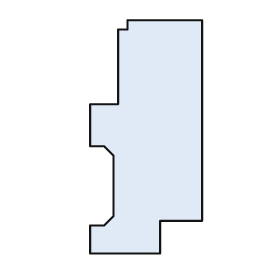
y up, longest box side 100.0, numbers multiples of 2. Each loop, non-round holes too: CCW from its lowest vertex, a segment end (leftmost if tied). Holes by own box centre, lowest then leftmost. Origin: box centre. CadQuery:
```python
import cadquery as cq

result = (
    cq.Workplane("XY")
    .moveTo(-24.0, -50.0)
    .lineTo(6.0, -50.0)
    .lineTo(6.0, -36.0)
    .lineTo(24.0, -36.0)
    .lineTo(24.0, 50.0)
    .lineTo(-8.0, 50.0)
    .lineTo(-8.0, 46.0)
    .lineTo(-12.0, 46.0)
    .lineTo(-12.0, 14.0)
    .lineTo(-24.0, 14.0)
    .lineTo(-24.0, -4.0)
    .lineTo(-18.0, -4.0)
    .lineTo(-14.0, -8.0)
    .lineTo(-14.0, -34.0)
    .lineTo(-18.0, -38.0)
    .lineTo(-24.0, -38.0)
    .close()
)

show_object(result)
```